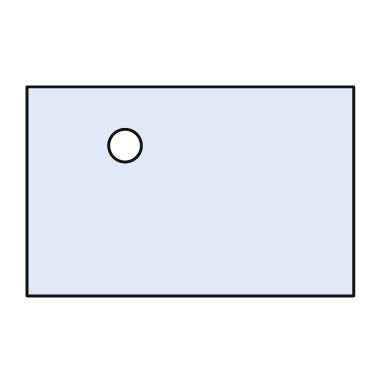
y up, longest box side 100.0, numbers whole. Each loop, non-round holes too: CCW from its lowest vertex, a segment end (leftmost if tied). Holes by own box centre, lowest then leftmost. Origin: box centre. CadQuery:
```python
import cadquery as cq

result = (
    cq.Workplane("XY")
    .moveTo(-50.0, -32.0)
    .lineTo(50.0, -32.0)
    .lineTo(50.0, 32.0)
    .lineTo(-50.0, 32.0)
    .close()
    .moveTo(-20.0, 14.0)
    .circle(5.0)
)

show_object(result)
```